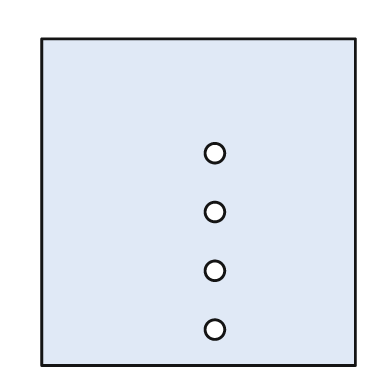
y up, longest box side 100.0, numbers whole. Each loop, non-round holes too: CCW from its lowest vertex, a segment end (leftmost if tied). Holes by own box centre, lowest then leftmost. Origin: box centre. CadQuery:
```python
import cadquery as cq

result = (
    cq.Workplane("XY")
    .moveTo(-48.0, -50.0)
    .lineTo(48.0, -50.0)
    .lineTo(48.0, 50.0)
    .lineTo(-48.0, 50.0)
    .close()
    .moveTo(5.0, -39.0)
    .circle(3.0)
    .moveTo(5.0, -21.0)
    .circle(3.0)
    .moveTo(5.0, -3.0)
    .circle(3.0)
    .moveTo(5.0, 15.0)
    .circle(3.0)
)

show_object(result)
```